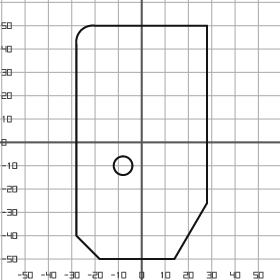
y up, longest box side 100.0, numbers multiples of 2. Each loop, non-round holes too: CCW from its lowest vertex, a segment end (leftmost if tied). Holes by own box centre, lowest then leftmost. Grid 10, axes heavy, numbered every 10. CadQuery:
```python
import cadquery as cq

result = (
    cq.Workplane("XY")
    .moveTo(-18.0, -50.0)
    .lineTo(14.0, -50.0)
    .lineTo(28.0, -26.0)
    .lineTo(28.0, 50.0)
    .lineTo(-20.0, 50.0)
    .threePointArc((-26.0, 48.0), (-28.0, 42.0))
    .lineTo(-28.0, -40.0)
    .close()
    .moveTo(-8.0, -10.0)
    .circle(4.0)
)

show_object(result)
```